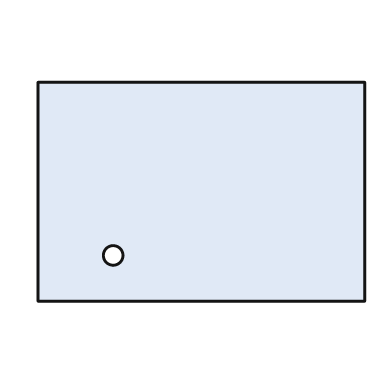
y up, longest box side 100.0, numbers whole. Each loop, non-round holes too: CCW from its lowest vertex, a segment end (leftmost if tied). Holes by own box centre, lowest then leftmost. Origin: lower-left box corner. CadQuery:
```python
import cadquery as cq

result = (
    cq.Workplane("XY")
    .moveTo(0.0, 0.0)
    .lineTo(100.0, 0.0)
    .lineTo(100.0, 67.0)
    .lineTo(0.0, 67.0)
    .close()
    .moveTo(23.0, 14.0)
    .circle(3.0)
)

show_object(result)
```